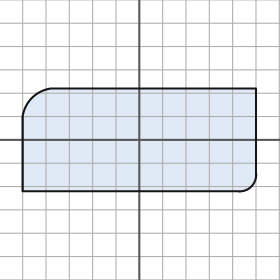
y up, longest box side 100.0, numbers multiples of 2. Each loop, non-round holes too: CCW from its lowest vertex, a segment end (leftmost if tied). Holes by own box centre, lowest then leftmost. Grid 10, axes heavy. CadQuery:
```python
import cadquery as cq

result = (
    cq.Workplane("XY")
    .moveTo(-50.0, -22.0)
    .lineTo(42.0, -22.0)
    .threePointArc((48.0, -20.0), (50.0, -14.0))
    .lineTo(50.0, 22.0)
    .lineTo(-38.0, 22.0)
    .threePointArc((-46.0, 18.0), (-50.0, 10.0))
    .close()
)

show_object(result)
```